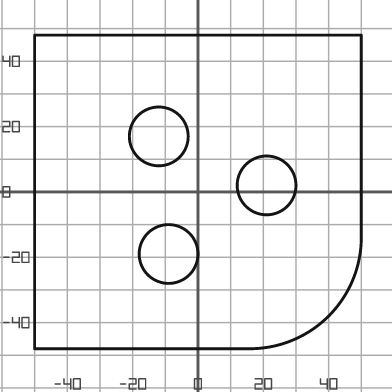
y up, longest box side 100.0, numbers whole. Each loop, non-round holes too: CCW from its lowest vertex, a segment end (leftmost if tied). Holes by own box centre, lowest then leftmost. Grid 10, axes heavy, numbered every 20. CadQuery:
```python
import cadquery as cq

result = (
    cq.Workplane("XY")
    .moveTo(-50.0, -48.0)
    .lineTo(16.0, -48.0)
    .threePointArc((40.0, -38.0), (50.0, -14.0))
    .lineTo(50.0, 48.0)
    .lineTo(-50.0, 48.0)
    .close()
    .moveTo(-9.0, -19.0)
    .circle(9.0)
    .moveTo(21.0, 2.0)
    .circle(9.0)
    .moveTo(-12.0, 17.0)
    .circle(9.0)
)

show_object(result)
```